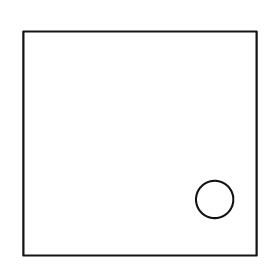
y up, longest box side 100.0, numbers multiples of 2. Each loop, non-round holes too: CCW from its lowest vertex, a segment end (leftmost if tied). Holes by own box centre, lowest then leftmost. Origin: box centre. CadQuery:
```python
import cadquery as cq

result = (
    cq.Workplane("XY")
    .moveTo(-50.0, -48.0)
    .lineTo(50.0, -48.0)
    .lineTo(50.0, 48.0)
    .lineTo(-50.0, 48.0)
    .close()
    .moveTo(32.0, -24.0)
    .circle(8.0)
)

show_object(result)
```